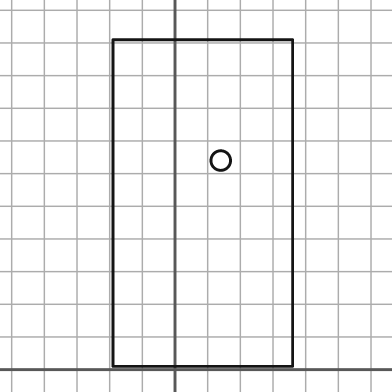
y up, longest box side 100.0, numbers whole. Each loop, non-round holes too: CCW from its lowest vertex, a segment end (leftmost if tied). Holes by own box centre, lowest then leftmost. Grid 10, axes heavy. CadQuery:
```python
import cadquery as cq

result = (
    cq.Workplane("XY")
    .moveTo(-19.0, 1.0)
    .lineTo(36.0, 1.0)
    .lineTo(36.0, 101.0)
    .lineTo(-19.0, 101.0)
    .close()
    .moveTo(14.0, 64.0)
    .circle(3.0)
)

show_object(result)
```